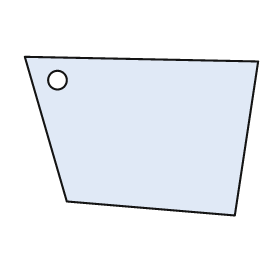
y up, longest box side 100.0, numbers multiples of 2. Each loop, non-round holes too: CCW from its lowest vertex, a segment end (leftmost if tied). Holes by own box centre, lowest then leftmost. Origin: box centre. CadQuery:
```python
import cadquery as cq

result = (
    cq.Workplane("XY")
    .moveTo(40.0, -34.0)
    .lineTo(50.0, 32.0)
    .lineTo(-50.0, 34.0)
    .lineTo(-32.0, -28.0)
    .close()
    .moveTo(-36.0, 24.0)
    .circle(4.0)
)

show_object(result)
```